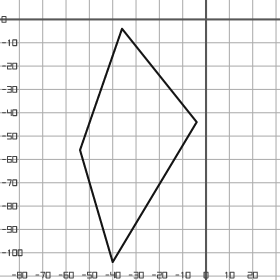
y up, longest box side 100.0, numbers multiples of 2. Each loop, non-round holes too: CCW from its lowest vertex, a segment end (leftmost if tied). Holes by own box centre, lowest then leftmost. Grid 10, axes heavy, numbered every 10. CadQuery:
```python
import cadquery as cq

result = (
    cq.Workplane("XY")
    .moveTo(-40.0, -104.0)
    .lineTo(-4.0, -44.0)
    .lineTo(-36.0, -4.0)
    .lineTo(-54.0, -56.0)
    .close()
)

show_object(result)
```